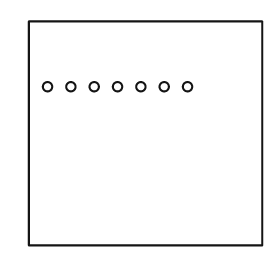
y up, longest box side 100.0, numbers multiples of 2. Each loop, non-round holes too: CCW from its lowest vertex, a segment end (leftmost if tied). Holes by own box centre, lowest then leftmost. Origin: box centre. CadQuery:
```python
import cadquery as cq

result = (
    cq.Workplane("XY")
    .moveTo(-50.0, -48.0)
    .lineTo(50.0, -48.0)
    .lineTo(50.0, 48.0)
    .lineTo(-50.0, 48.0)
    .close()
    .moveTo(-42.0, 20.0)
    .circle(2.0)
    .moveTo(-32.0, 20.0)
    .circle(2.0)
    .moveTo(-22.0, 20.0)
    .circle(2.0)
    .moveTo(-12.0, 20.0)
    .circle(2.0)
    .moveTo(-2.0, 20.0)
    .circle(2.0)
    .moveTo(8.0, 20.0)
    .circle(2.0)
    .moveTo(18.0, 20.0)
    .circle(2.0)
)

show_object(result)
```